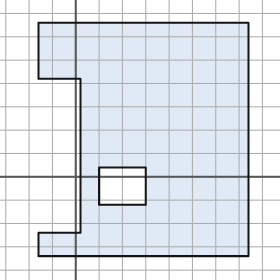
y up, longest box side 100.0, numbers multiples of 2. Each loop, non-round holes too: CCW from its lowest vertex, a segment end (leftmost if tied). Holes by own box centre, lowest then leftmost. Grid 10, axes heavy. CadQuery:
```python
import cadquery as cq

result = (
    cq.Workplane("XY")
    .moveTo(-16.0, -34.0)
    .lineTo(74.0, -34.0)
    .lineTo(74.0, 66.0)
    .lineTo(-16.0, 66.0)
    .lineTo(-16.0, 42.0)
    .lineTo(2.0, 42.0)
    .lineTo(2.0, -24.0)
    .lineTo(-16.0, -24.0)
    .close()
    .moveTo(10.0, -12.0)
    .lineTo(30.0, -12.0)
    .lineTo(30.0, 4.0)
    .lineTo(10.0, 4.0)
    .close()
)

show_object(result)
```